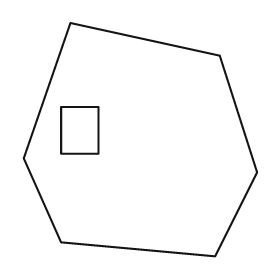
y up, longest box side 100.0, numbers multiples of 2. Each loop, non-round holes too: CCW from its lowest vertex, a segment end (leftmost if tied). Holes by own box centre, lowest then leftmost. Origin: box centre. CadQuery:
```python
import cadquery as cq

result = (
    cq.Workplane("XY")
    .moveTo(32.0, -50.0)
    .lineTo(50.0, -14.0)
    .lineTo(34.0, 36.0)
    .lineTo(-30.0, 50.0)
    .lineTo(-50.0, -8.0)
    .lineTo(-34.0, -44.0)
    .close()
    .moveTo(-34.0, -6.0)
    .lineTo(-18.0, -6.0)
    .lineTo(-18.0, 14.0)
    .lineTo(-34.0, 14.0)
    .close()
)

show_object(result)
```